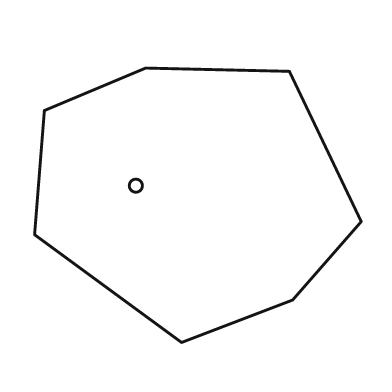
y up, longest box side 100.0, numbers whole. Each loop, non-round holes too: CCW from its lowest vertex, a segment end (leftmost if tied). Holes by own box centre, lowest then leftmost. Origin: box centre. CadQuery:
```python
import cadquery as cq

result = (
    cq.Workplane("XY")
    .moveTo(-5.0, -42.0)
    .lineTo(29.0, -29.0)
    .lineTo(50.0, -5.0)
    .lineTo(28.0, 41.0)
    .lineTo(-16.0, 42.0)
    .lineTo(-47.0, 29.0)
    .lineTo(-50.0, -9.0)
    .close()
    .moveTo(-19.0, 6.0)
    .circle(2.0)
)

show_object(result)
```